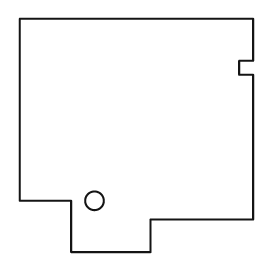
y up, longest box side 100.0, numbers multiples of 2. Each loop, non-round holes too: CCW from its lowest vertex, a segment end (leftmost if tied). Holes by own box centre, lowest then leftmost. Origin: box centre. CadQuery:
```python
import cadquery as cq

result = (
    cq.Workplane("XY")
    .moveTo(-28.0, -50.0)
    .lineTo(6.0, -50.0)
    .lineTo(6.0, -36.0)
    .lineTo(50.0, -36.0)
    .lineTo(50.0, 26.0)
    .lineTo(44.0, 26.0)
    .lineTo(44.0, 32.0)
    .lineTo(50.0, 32.0)
    .lineTo(50.0, 50.0)
    .lineTo(-50.0, 50.0)
    .lineTo(-50.0, -28.0)
    .lineTo(-28.0, -28.0)
    .close()
    .moveTo(-18.0, -28.0)
    .circle(4.0)
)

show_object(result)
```